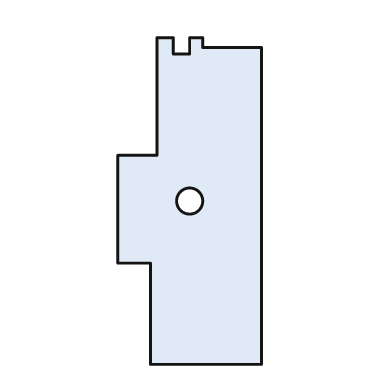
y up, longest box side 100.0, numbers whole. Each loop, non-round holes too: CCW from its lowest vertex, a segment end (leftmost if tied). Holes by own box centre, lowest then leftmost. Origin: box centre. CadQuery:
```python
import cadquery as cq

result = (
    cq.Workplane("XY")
    .moveTo(-12.0, -50.0)
    .lineTo(22.0, -50.0)
    .lineTo(22.0, 47.0)
    .lineTo(4.0, 47.0)
    .lineTo(4.0, 50.0)
    .lineTo(0.0, 50.0)
    .lineTo(0.0, 45.0)
    .lineTo(-5.0, 45.0)
    .lineTo(-5.0, 50.0)
    .lineTo(-10.0, 50.0)
    .lineTo(-10.0, 14.0)
    .lineTo(-22.0, 14.0)
    .lineTo(-22.0, -19.0)
    .lineTo(-12.0, -19.0)
    .close()
    .moveTo(0.0, 0.0)
    .circle(4.0)
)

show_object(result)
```